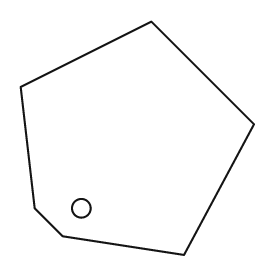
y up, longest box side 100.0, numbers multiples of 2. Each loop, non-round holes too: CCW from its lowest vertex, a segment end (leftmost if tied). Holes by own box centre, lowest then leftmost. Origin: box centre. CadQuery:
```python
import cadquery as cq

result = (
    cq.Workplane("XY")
    .moveTo(20.0, -50.0)
    .lineTo(50.0, 6.0)
    .lineTo(6.0, 50.0)
    .lineTo(-50.0, 22.0)
    .lineTo(-44.0, -30.0)
    .lineTo(-32.0, -42.0)
    .close()
    .moveTo(-24.0, -30.0)
    .circle(4.0)
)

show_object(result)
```